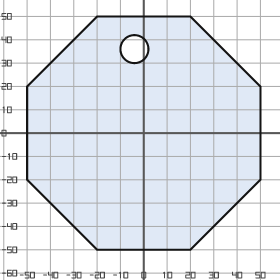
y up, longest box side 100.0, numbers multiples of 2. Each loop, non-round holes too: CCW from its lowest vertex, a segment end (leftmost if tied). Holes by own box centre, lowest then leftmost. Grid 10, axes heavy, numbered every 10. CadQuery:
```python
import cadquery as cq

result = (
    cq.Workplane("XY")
    .moveTo(-20.0, -50.0)
    .lineTo(20.0, -50.0)
    .lineTo(50.0, -20.0)
    .lineTo(50.0, 20.0)
    .lineTo(20.0, 50.0)
    .lineTo(-20.0, 50.0)
    .lineTo(-50.0, 20.0)
    .lineTo(-50.0, -20.0)
    .close()
    .moveTo(-4.0, 36.0)
    .circle(6.0)
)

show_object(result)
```